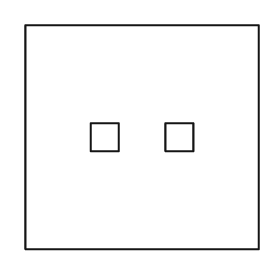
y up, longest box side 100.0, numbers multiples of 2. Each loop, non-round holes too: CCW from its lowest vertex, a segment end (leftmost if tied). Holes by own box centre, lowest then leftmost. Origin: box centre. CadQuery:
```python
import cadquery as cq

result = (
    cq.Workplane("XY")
    .moveTo(-50.0, -48.0)
    .lineTo(50.0, -48.0)
    .lineTo(50.0, 48.0)
    .lineTo(-50.0, 48.0)
    .close()
    .moveTo(-22.0, -6.0)
    .lineTo(-10.0, -6.0)
    .lineTo(-10.0, 6.0)
    .lineTo(-22.0, 6.0)
    .close()
    .moveTo(10.0, -6.0)
    .lineTo(22.0, -6.0)
    .lineTo(22.0, 6.0)
    .lineTo(10.0, 6.0)
    .close()
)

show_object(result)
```